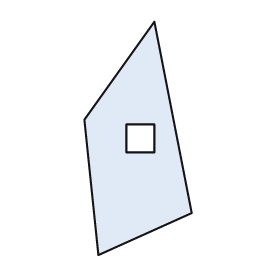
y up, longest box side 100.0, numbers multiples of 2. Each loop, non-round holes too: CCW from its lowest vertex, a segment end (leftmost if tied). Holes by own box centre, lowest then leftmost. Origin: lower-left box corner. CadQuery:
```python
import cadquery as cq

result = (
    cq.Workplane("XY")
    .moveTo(6.0, 0.0)
    .lineTo(46.0, 18.0)
    .lineTo(30.0, 100.0)
    .lineTo(0.0, 58.0)
    .close()
    .moveTo(18.0, 44.0)
    .lineTo(30.0, 44.0)
    .lineTo(30.0, 56.0)
    .lineTo(18.0, 56.0)
    .close()
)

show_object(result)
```